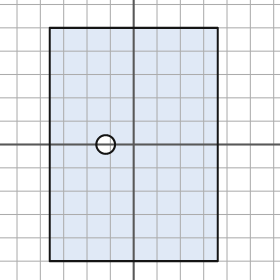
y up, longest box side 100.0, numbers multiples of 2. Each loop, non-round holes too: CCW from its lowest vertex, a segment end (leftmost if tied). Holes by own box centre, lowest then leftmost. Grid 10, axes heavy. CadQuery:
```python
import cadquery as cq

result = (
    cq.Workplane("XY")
    .moveTo(-36.0, -50.0)
    .lineTo(36.0, -50.0)
    .lineTo(36.0, 50.0)
    .lineTo(-36.0, 50.0)
    .close()
    .moveTo(-12.0, 0.0)
    .circle(4.0)
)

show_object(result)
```